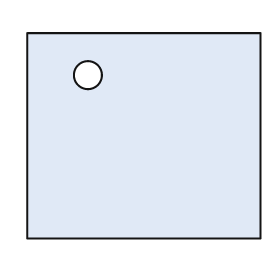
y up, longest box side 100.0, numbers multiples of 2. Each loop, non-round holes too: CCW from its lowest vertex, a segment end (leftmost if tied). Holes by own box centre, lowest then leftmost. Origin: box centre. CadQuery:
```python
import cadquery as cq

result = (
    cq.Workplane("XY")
    .moveTo(-50.0, -44.0)
    .lineTo(50.0, -44.0)
    .lineTo(50.0, 44.0)
    .lineTo(-50.0, 44.0)
    .close()
    .moveTo(-24.0, 26.0)
    .circle(6.0)
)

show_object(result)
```